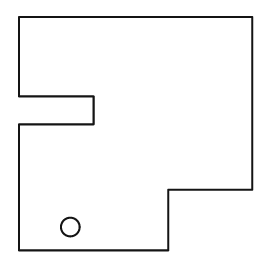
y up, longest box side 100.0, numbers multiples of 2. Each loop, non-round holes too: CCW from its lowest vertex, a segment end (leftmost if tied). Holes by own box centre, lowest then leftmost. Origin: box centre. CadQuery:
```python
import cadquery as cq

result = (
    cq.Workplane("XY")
    .moveTo(-50.0, -50.0)
    .lineTo(14.0, -50.0)
    .lineTo(14.0, -24.0)
    .lineTo(50.0, -24.0)
    .lineTo(50.0, 50.0)
    .lineTo(-50.0, 50.0)
    .lineTo(-50.0, 16.0)
    .lineTo(-18.0, 16.0)
    .lineTo(-18.0, 4.0)
    .lineTo(-50.0, 4.0)
    .close()
    .moveTo(-28.0, -40.0)
    .circle(4.0)
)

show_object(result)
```